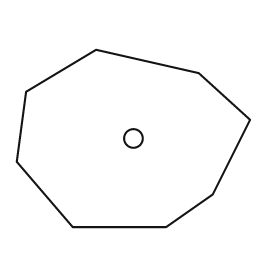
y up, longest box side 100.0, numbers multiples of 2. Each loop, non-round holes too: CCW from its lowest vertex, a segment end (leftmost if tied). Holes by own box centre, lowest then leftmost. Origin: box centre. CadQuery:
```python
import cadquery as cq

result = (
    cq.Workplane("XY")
    .moveTo(-26.0, -38.0)
    .lineTo(14.0, -38.0)
    .lineTo(34.0, -24.0)
    .lineTo(50.0, 8.0)
    .lineTo(28.0, 28.0)
    .lineTo(-16.0, 38.0)
    .lineTo(-46.0, 20.0)
    .lineTo(-50.0, -10.0)
    .close()
    .moveTo(0.0, 0.0)
    .circle(4.0)
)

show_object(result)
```